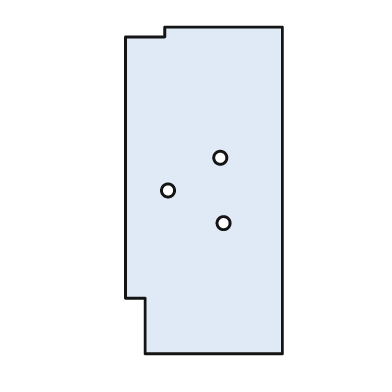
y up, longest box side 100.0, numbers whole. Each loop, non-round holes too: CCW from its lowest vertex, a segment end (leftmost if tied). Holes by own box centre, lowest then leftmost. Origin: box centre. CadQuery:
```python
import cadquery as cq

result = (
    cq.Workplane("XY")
    .moveTo(-18.0, -50.0)
    .lineTo(24.0, -50.0)
    .lineTo(24.0, 50.0)
    .lineTo(-12.0, 50.0)
    .lineTo(-12.0, 47.0)
    .lineTo(-24.0, 47.0)
    .lineTo(-24.0, -33.0)
    .lineTo(-18.0, -33.0)
    .close()
    .moveTo(6.0, -10.0)
    .circle(2.0)
    .moveTo(-11.0, 0.0)
    .circle(2.0)
    .moveTo(5.0, 10.0)
    .circle(2.0)
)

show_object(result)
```